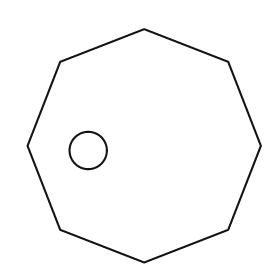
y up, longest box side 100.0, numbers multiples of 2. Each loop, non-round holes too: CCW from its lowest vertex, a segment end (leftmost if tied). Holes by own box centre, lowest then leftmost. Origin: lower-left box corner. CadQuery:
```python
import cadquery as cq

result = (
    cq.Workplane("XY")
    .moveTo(50.0, 0.0)
    .lineTo(86.0, 14.0)
    .lineTo(100.0, 50.0)
    .lineTo(86.0, 86.0)
    .lineTo(50.0, 100.0)
    .lineTo(14.0, 86.0)
    .lineTo(0.0, 50.0)
    .lineTo(14.0, 14.0)
    .close()
    .moveTo(26.0, 48.0)
    .circle(8.0)
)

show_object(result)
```